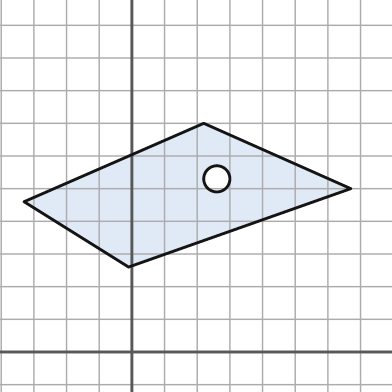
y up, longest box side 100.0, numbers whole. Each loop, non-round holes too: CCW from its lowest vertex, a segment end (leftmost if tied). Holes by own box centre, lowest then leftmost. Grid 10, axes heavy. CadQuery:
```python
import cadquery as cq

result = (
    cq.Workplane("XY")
    .moveTo(-1.0, 26.0)
    .lineTo(67.0, 50.0)
    .lineTo(22.0, 70.0)
    .lineTo(-33.0, 46.0)
    .close()
    .moveTo(26.0, 53.0)
    .circle(4.0)
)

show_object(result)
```